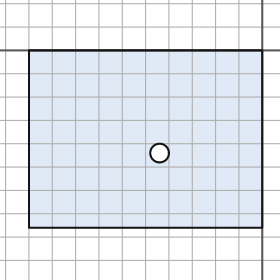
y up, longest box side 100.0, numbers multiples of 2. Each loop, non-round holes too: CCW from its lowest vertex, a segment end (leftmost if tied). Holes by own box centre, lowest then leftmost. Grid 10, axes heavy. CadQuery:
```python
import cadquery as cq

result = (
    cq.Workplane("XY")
    .moveTo(-100.0, -76.0)
    .lineTo(0.0, -76.0)
    .lineTo(0.0, 0.0)
    .lineTo(-100.0, 0.0)
    .close()
    .moveTo(-44.0, -44.0)
    .circle(4.0)
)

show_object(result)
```